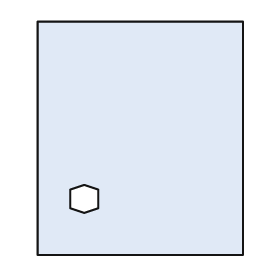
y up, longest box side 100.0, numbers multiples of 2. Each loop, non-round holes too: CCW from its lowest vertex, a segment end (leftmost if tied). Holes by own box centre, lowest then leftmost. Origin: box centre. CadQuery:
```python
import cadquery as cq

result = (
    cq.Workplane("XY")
    .moveTo(-44.0, -50.0)
    .lineTo(44.0, -50.0)
    .lineTo(44.0, 50.0)
    .lineTo(-44.0, 50.0)
    .close()
    .moveTo(-24.0, -32.0)
    .lineTo(-18.0, -30.0)
    .lineTo(-18.0, -22.0)
    .lineTo(-24.0, -20.0)
    .lineTo(-30.0, -22.0)
    .lineTo(-30.0, -30.0)
    .close()
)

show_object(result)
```